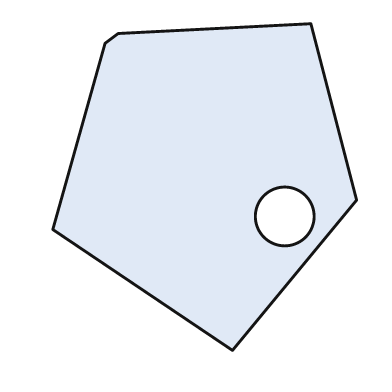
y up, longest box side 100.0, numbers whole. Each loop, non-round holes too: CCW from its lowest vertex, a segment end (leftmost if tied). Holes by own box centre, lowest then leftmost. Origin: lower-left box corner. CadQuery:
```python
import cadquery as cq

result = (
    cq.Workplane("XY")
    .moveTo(55.0, 0.0)
    .lineTo(93.0, 46.0)
    .lineTo(79.0, 100.0)
    .lineTo(20.0, 97.0)
    .lineTo(16.0, 94.0)
    .lineTo(0.0, 37.0)
    .close()
    .moveTo(71.0, 41.0)
    .circle(9.0)
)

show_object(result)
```